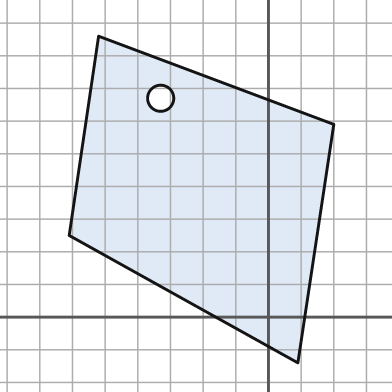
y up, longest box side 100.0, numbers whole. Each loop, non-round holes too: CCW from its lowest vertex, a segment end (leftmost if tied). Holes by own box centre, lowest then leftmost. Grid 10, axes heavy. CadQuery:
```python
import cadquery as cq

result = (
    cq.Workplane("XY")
    .moveTo(9.0, -14.0)
    .lineTo(20.0, 59.0)
    .lineTo(-52.0, 86.0)
    .lineTo(-61.0, 25.0)
    .close()
    .moveTo(-33.0, 67.0)
    .circle(4.0)
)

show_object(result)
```